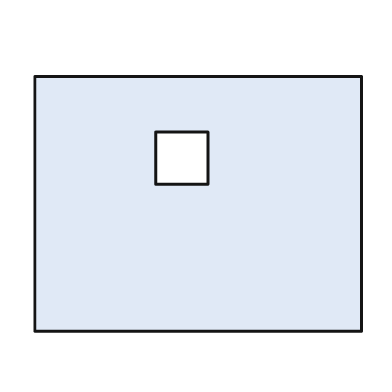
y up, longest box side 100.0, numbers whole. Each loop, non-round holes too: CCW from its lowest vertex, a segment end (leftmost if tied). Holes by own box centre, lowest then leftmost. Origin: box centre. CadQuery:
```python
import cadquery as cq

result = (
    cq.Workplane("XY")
    .moveTo(-50.0, -39.0)
    .lineTo(50.0, -39.0)
    .lineTo(50.0, 39.0)
    .lineTo(-50.0, 39.0)
    .close()
    .moveTo(-13.0, 6.0)
    .lineTo(3.0, 6.0)
    .lineTo(3.0, 22.0)
    .lineTo(-13.0, 22.0)
    .close()
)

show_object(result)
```